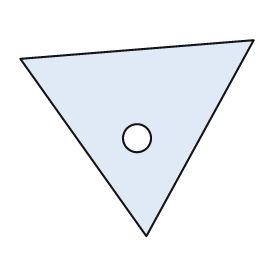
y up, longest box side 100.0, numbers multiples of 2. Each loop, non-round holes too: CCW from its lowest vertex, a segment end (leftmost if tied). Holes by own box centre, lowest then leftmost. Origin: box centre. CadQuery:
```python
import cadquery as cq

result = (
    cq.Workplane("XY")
    .moveTo(4.0, -42.0)
    .lineTo(50.0, 42.0)
    .lineTo(-50.0, 34.0)
    .close()
    .moveTo(0.0, 0.0)
    .circle(6.0)
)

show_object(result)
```